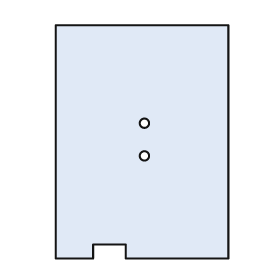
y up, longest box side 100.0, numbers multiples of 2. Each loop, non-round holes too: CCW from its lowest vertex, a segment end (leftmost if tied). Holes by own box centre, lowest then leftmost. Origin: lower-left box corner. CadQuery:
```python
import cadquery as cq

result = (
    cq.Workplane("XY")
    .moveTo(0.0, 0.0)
    .lineTo(16.0, 0.0)
    .lineTo(16.0, 6.0)
    .lineTo(30.0, 6.0)
    .lineTo(30.0, 0.0)
    .lineTo(74.0, 0.0)
    .lineTo(74.0, 100.0)
    .lineTo(0.0, 100.0)
    .close()
    .moveTo(38.0, 44.0)
    .circle(2.0)
    .moveTo(38.0, 58.0)
    .circle(2.0)
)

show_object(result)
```